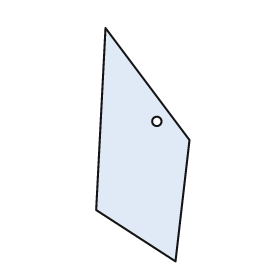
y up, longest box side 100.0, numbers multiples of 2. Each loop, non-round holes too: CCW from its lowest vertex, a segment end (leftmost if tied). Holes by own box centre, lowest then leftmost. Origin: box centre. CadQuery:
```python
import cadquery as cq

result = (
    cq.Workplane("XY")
    .moveTo(14.0, -50.0)
    .lineTo(20.0, 2.0)
    .lineTo(-16.0, 50.0)
    .lineTo(-20.0, -28.0)
    .close()
    .moveTo(6.0, 10.0)
    .circle(2.0)
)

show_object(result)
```